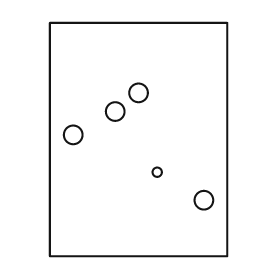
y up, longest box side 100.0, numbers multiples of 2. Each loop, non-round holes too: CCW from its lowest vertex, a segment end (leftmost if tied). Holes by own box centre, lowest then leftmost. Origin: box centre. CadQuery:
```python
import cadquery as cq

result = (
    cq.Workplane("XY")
    .moveTo(-38.0, -50.0)
    .lineTo(38.0, -50.0)
    .lineTo(38.0, 50.0)
    .lineTo(-38.0, 50.0)
    .close()
    .moveTo(28.0, -26.0)
    .circle(4.0)
    .moveTo(8.0, -14.0)
    .circle(2.0)
    .moveTo(-28.0, 2.0)
    .circle(4.0)
    .moveTo(-10.0, 12.0)
    .circle(4.0)
    .moveTo(0.0, 20.0)
    .circle(4.0)
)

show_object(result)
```